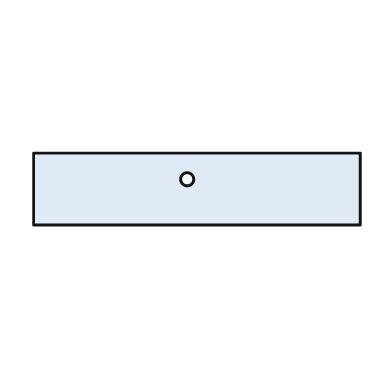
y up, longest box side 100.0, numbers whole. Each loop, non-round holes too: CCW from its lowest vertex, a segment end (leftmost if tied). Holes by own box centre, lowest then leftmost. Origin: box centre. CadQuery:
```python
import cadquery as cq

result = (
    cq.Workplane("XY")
    .moveTo(-50.0, -11.0)
    .lineTo(50.0, -11.0)
    .lineTo(50.0, 11.0)
    .lineTo(-50.0, 11.0)
    .close()
    .moveTo(-3.0, 3.0)
    .circle(2.0)
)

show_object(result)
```